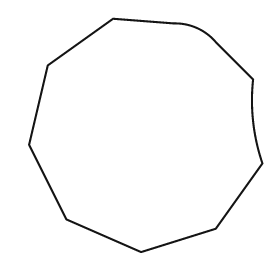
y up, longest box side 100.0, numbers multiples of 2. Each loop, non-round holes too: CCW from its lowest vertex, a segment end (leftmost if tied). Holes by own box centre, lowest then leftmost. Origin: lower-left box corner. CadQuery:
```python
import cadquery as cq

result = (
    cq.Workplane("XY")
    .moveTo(48.0, 0.0)
    .lineTo(80.0, 10.0)
    .lineTo(100.0, 38.0)
    .threePointArc((96.0, 56.0), (96.0, 74.0))
    .lineTo(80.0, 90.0)
    .threePointArc((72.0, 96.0), (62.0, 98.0))
    .lineTo(36.0, 100.0)
    .lineTo(8.0, 80.0)
    .lineTo(0.0, 46.0)
    .lineTo(16.0, 14.0)
    .close()
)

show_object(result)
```